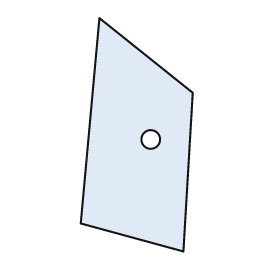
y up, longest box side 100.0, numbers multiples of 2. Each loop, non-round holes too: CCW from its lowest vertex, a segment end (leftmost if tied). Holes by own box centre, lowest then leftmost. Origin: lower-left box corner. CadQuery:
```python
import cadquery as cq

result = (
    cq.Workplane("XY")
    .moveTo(44.0, 0.0)
    .lineTo(48.0, 68.0)
    .lineTo(8.0, 100.0)
    .lineTo(0.0, 12.0)
    .close()
    .moveTo(30.0, 48.0)
    .circle(4.0)
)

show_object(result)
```